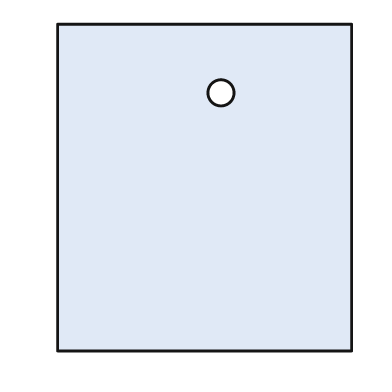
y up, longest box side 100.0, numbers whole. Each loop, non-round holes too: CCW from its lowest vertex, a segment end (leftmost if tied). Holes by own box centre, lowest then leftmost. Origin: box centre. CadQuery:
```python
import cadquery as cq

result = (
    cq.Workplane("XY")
    .moveTo(-45.0, -50.0)
    .lineTo(45.0, -50.0)
    .lineTo(45.0, 50.0)
    .lineTo(-45.0, 50.0)
    .close()
    .moveTo(5.0, 29.0)
    .circle(4.0)
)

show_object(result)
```